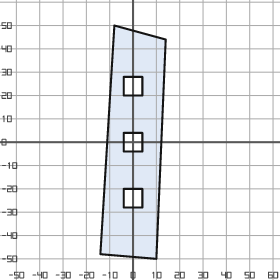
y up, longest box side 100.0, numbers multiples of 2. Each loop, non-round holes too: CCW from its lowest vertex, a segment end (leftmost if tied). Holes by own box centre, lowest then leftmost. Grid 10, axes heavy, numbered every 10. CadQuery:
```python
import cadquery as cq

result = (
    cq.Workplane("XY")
    .moveTo(10.0, -50.0)
    .lineTo(14.0, 44.0)
    .lineTo(-8.0, 50.0)
    .lineTo(-14.0, -48.0)
    .close()
    .moveTo(-4.0, -28.0)
    .lineTo(4.0, -28.0)
    .lineTo(4.0, -20.0)
    .lineTo(-4.0, -20.0)
    .close()
    .moveTo(-4.0, -4.0)
    .lineTo(4.0, -4.0)
    .lineTo(4.0, 4.0)
    .lineTo(-4.0, 4.0)
    .close()
    .moveTo(-4.0, 20.0)
    .lineTo(4.0, 20.0)
    .lineTo(4.0, 28.0)
    .lineTo(-4.0, 28.0)
    .close()
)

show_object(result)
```